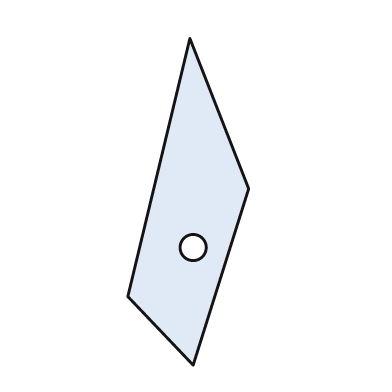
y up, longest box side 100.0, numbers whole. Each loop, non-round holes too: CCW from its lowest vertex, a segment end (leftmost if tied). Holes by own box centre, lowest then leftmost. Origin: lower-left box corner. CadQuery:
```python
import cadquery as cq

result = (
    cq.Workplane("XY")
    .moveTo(20.0, 0.0)
    .lineTo(37.0, 54.0)
    .lineTo(19.0, 100.0)
    .lineTo(0.0, 21.0)
    .close()
    .moveTo(20.0, 36.0)
    .circle(4.0)
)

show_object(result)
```